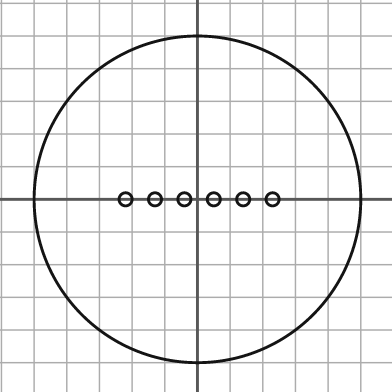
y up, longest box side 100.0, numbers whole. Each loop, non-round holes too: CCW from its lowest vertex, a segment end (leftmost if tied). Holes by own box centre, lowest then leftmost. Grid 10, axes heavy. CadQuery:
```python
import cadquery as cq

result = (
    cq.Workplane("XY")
    .moveTo(0.0, 0.0)
    .circle(50.0)
    .moveTo(-22.0, 0.0)
    .circle(2.0)
    .moveTo(-13.0, 0.0)
    .circle(2.0)
    .moveTo(-4.0, 0.0)
    .circle(2.0)
    .moveTo(5.0, 0.0)
    .circle(2.0)
    .moveTo(14.0, 0.0)
    .circle(2.0)
    .moveTo(23.0, 0.0)
    .circle(2.0)
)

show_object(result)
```